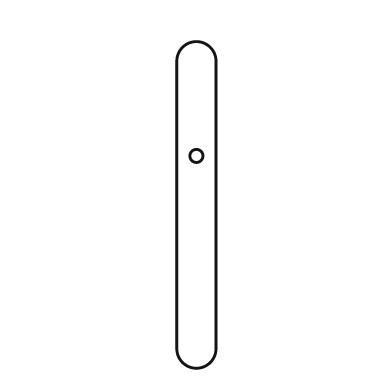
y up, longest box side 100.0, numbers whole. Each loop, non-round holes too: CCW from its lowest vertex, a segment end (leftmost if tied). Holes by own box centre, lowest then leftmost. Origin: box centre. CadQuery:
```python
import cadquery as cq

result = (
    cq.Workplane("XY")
    .moveTo(-6.0, -44.0)
    .threePointArc((0.0, -50.0), (6.0, -44.0))
    .lineTo(6.0, 44.0)
    .threePointArc((0.0, 50.0), (-6.0, 44.0))
    .close()
    .moveTo(0.0, 15.0)
    .circle(2.0)
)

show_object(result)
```